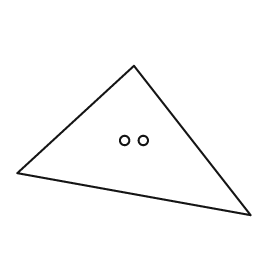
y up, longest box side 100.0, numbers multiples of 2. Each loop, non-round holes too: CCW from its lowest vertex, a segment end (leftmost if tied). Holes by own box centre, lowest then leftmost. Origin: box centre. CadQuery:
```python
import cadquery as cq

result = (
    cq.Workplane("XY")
    .moveTo(50.0, -32.0)
    .lineTo(0.0, 32.0)
    .lineTo(-50.0, -14.0)
    .close()
    .moveTo(-4.0, 0.0)
    .circle(2.0)
    .moveTo(4.0, 0.0)
    .circle(2.0)
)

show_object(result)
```